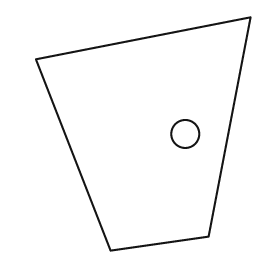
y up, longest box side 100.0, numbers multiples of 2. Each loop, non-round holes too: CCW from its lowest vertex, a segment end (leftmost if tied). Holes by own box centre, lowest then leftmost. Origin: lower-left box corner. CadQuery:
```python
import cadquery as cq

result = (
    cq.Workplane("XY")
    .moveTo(32.0, 0.0)
    .lineTo(74.0, 6.0)
    .lineTo(92.0, 100.0)
    .lineTo(0.0, 82.0)
    .close()
    .moveTo(64.0, 50.0)
    .circle(6.0)
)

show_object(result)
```